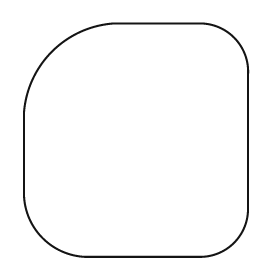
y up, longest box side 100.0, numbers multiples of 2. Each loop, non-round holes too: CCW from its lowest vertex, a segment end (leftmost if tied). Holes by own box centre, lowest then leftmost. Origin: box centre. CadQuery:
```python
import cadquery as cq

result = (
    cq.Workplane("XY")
    .moveTo(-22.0, -50.0)
    .lineTo(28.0, -50.0)
    .threePointArc((42.0, -44.0), (48.0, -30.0))
    .lineTo(48.0, 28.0)
    .threePointArc((42.0, 44.0), (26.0, 50.0))
    .lineTo(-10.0, 50.0)
    .threePointArc((-36.0, 38.0), (-48.0, 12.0))
    .lineTo(-48.0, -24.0)
    .threePointArc((-40.0, -42.0), (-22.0, -50.0))
    .close()
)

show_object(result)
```